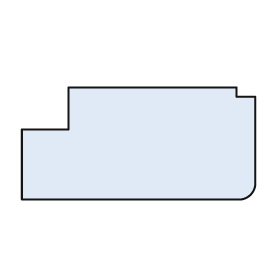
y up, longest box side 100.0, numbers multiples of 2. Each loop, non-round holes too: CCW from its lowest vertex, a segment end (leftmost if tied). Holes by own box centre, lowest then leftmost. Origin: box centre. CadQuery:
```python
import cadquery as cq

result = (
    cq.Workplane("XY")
    .moveTo(-50.0, -24.0)
    .lineTo(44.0, -24.0)
    .threePointArc((48.0, -22.0), (50.0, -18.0))
    .lineTo(50.0, 20.0)
    .lineTo(42.0, 20.0)
    .lineTo(42.0, 24.0)
    .lineTo(-30.0, 24.0)
    .lineTo(-30.0, 6.0)
    .lineTo(-50.0, 6.0)
    .close()
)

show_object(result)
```